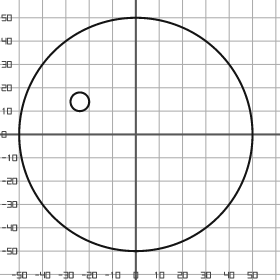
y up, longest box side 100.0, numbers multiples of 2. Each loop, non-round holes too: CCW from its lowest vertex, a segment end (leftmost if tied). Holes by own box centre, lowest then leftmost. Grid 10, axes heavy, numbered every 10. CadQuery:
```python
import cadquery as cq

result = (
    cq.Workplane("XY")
    .moveTo(0.0, 0.0)
    .circle(50.0)
    .moveTo(-24.0, 14.0)
    .circle(4.0)
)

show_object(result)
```